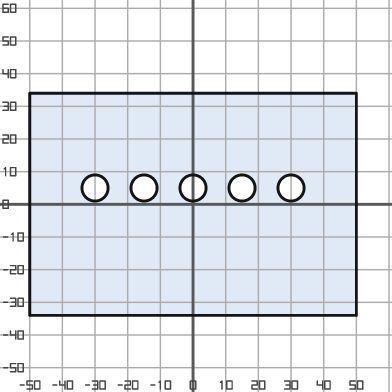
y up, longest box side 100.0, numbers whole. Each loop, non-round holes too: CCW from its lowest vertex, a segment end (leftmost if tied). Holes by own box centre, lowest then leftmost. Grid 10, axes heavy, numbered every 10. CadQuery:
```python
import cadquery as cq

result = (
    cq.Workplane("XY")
    .moveTo(-50.0, -34.0)
    .lineTo(50.0, -34.0)
    .lineTo(50.0, 34.0)
    .lineTo(-50.0, 34.0)
    .close()
    .moveTo(-30.0, 5.0)
    .circle(4.0)
    .moveTo(-15.0, 5.0)
    .circle(4.0)
    .moveTo(0.0, 5.0)
    .circle(4.0)
    .moveTo(15.0, 5.0)
    .circle(4.0)
    .moveTo(30.0, 5.0)
    .circle(4.0)
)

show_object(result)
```